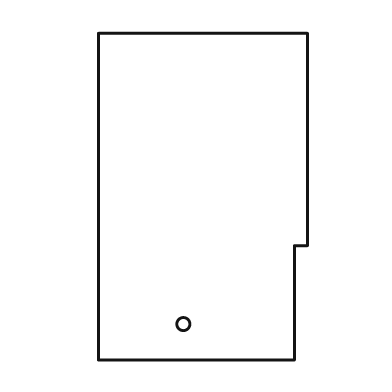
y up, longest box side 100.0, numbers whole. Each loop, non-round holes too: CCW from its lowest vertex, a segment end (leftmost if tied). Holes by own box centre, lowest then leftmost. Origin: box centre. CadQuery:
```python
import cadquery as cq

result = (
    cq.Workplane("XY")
    .moveTo(-32.0, -50.0)
    .lineTo(28.0, -50.0)
    .lineTo(28.0, -15.0)
    .lineTo(32.0, -15.0)
    .lineTo(32.0, 50.0)
    .lineTo(-32.0, 50.0)
    .close()
    .moveTo(-6.0, -39.0)
    .circle(2.0)
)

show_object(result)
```